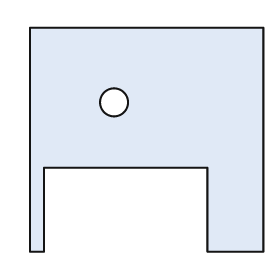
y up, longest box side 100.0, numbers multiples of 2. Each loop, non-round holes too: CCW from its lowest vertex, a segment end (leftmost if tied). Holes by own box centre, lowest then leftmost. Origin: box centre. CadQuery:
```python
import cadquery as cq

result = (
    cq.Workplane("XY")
    .moveTo(-50.0, -48.0)
    .lineTo(-44.0, -48.0)
    .lineTo(-44.0, -12.0)
    .lineTo(26.0, -12.0)
    .lineTo(26.0, -48.0)
    .lineTo(50.0, -48.0)
    .lineTo(50.0, 48.0)
    .lineTo(-50.0, 48.0)
    .close()
    .moveTo(-14.0, 16.0)
    .circle(6.0)
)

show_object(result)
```